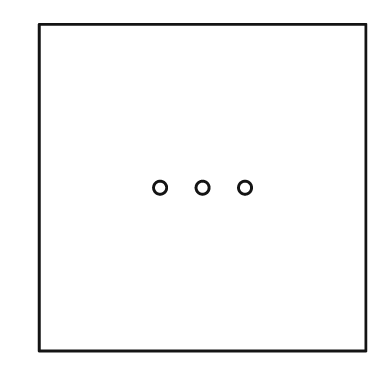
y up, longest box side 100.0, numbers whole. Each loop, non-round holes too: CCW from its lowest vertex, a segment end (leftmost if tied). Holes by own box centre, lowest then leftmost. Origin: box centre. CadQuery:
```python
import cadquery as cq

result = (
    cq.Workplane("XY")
    .moveTo(-50.0, -50.0)
    .lineTo(50.0, -50.0)
    .lineTo(50.0, 50.0)
    .lineTo(-50.0, 50.0)
    .close()
    .moveTo(-13.0, 0.0)
    .circle(2.0)
    .moveTo(0.0, 0.0)
    .circle(2.0)
    .moveTo(13.0, 0.0)
    .circle(2.0)
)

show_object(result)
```